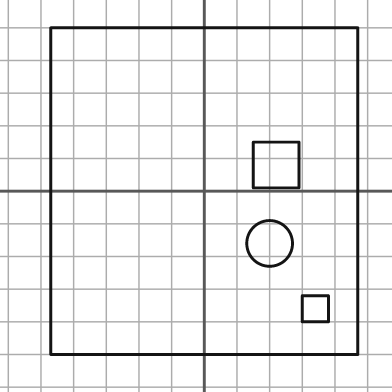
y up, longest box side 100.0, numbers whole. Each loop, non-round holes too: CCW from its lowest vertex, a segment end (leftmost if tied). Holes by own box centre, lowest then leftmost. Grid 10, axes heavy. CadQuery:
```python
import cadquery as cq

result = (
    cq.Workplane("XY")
    .moveTo(-47.0, -50.0)
    .lineTo(47.0, -50.0)
    .lineTo(47.0, 50.0)
    .lineTo(-47.0, 50.0)
    .close()
    .moveTo(30.0, -40.0)
    .lineTo(38.0, -40.0)
    .lineTo(38.0, -32.0)
    .lineTo(30.0, -32.0)
    .close()
    .moveTo(20.0, -16.0)
    .circle(7.0)
    .moveTo(15.0, 1.0)
    .lineTo(29.0, 1.0)
    .lineTo(29.0, 15.0)
    .lineTo(15.0, 15.0)
    .close()
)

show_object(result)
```